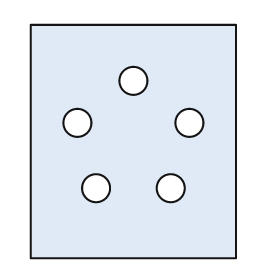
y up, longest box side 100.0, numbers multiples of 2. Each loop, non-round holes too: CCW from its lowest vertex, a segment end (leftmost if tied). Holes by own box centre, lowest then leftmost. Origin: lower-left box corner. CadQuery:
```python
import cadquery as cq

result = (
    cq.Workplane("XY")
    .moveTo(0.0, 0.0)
    .lineTo(88.0, 0.0)
    .lineTo(88.0, 100.0)
    .lineTo(0.0, 100.0)
    .close()
    .moveTo(28.0, 30.0)
    .circle(6.0)
    .moveTo(60.0, 30.0)
    .circle(6.0)
    .moveTo(20.0, 58.0)
    .circle(6.0)
    .moveTo(68.0, 58.0)
    .circle(6.0)
    .moveTo(44.0, 76.0)
    .circle(6.0)
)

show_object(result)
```